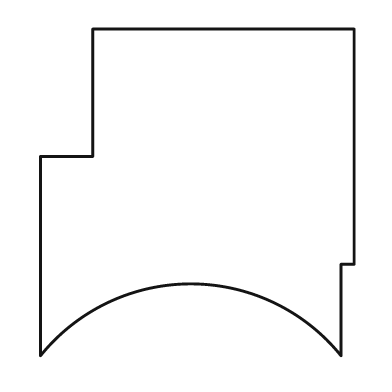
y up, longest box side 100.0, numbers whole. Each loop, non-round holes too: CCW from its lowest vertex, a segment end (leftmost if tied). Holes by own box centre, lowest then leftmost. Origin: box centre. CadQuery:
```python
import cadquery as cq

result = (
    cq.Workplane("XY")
    .moveTo(-48.0, -50.0)
    .threePointArc((-2.0, -28.0), (44.0, -50.0))
    .lineTo(44.0, -22.0)
    .lineTo(48.0, -22.0)
    .lineTo(48.0, 50.0)
    .lineTo(-32.0, 50.0)
    .lineTo(-32.0, 11.0)
    .lineTo(-48.0, 11.0)
    .close()
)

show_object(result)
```